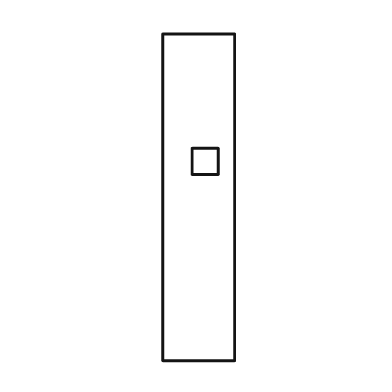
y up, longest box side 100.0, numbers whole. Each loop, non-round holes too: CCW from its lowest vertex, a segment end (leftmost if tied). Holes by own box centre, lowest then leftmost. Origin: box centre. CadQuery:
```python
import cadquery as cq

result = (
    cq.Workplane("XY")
    .moveTo(-11.0, -50.0)
    .lineTo(11.0, -50.0)
    .lineTo(11.0, 50.0)
    .lineTo(-11.0, 50.0)
    .close()
    .moveTo(-2.0, 7.0)
    .lineTo(6.0, 7.0)
    .lineTo(6.0, 15.0)
    .lineTo(-2.0, 15.0)
    .close()
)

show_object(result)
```